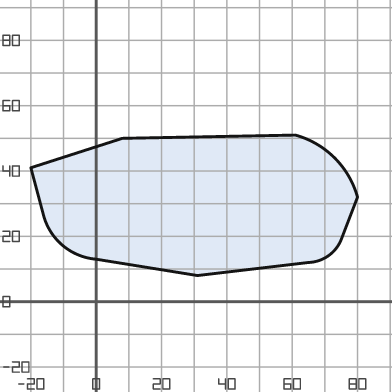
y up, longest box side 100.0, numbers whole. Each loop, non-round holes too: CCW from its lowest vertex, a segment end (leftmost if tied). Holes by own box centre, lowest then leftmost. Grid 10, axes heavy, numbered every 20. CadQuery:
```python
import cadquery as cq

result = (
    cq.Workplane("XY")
    .moveTo(31.0, 8.0)
    .lineTo(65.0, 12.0)
    .threePointArc((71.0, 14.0), (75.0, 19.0))
    .lineTo(80.0, 32.0)
    .threePointArc((73.0, 44.0), (61.0, 51.0))
    .lineTo(8.0, 50.0)
    .lineTo(-20.0, 41.0)
    .lineTo(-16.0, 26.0)
    .threePointArc((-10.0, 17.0), (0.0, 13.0))
    .close()
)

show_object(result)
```